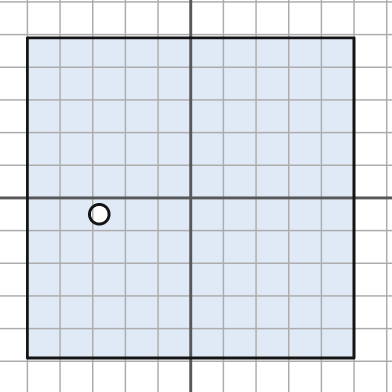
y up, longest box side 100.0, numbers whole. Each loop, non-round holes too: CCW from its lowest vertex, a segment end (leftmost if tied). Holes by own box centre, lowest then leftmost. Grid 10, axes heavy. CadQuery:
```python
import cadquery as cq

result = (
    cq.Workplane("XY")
    .moveTo(-50.0, -49.0)
    .lineTo(50.0, -49.0)
    .lineTo(50.0, 49.0)
    .lineTo(-50.0, 49.0)
    .close()
    .moveTo(-28.0, -5.0)
    .circle(3.0)
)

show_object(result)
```